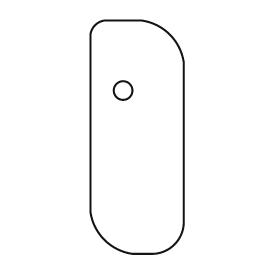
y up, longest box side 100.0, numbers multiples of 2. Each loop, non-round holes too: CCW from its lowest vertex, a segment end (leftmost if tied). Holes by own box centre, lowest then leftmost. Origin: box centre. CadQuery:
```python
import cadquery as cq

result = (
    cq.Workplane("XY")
    .moveTo(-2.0, -50.0)
    .lineTo(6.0, -50.0)
    .threePointArc((16.0, -46.0), (20.0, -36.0))
    .lineTo(20.0, 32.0)
    .threePointArc((14.0, 44.0), (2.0, 50.0))
    .lineTo(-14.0, 50.0)
    .threePointArc((-18.0, 48.0), (-20.0, 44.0))
    .lineTo(-20.0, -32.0)
    .threePointArc((-14.0, -44.0), (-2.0, -50.0))
    .close()
    .moveTo(-6.0, 20.0)
    .circle(4.0)
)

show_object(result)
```